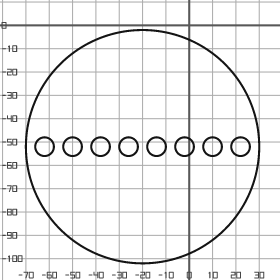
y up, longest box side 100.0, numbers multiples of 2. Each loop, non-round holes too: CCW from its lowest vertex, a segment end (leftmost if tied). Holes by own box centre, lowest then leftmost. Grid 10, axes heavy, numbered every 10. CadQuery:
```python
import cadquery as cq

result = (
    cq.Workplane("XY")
    .moveTo(-20.0, -52.0)
    .circle(50.0)
    .moveTo(-62.0, -52.0)
    .circle(4.0)
    .moveTo(-50.0, -52.0)
    .circle(4.0)
    .moveTo(-38.0, -52.0)
    .circle(4.0)
    .moveTo(-26.0, -52.0)
    .circle(4.0)
    .moveTo(-14.0, -52.0)
    .circle(4.0)
    .moveTo(-2.0, -52.0)
    .circle(4.0)
    .moveTo(10.0, -52.0)
    .circle(4.0)
    .moveTo(22.0, -52.0)
    .circle(4.0)
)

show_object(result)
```